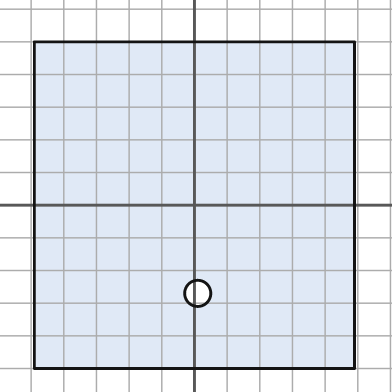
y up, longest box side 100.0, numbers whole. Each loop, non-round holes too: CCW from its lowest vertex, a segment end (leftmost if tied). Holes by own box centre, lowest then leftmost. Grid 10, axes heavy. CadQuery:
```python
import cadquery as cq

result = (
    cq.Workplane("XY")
    .moveTo(-49.0, -50.0)
    .lineTo(49.0, -50.0)
    .lineTo(49.0, 50.0)
    .lineTo(-49.0, 50.0)
    .close()
    .moveTo(1.0, -27.0)
    .circle(4.0)
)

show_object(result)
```